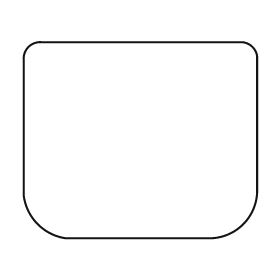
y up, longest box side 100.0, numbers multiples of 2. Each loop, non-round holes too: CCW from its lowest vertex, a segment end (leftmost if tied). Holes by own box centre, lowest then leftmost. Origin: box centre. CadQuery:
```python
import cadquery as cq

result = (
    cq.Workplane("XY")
    .moveTo(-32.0, -42.0)
    .lineTo(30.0, -42.0)
    .threePointArc((44.0, -36.0), (50.0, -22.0))
    .lineTo(50.0, 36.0)
    .threePointArc((48.0, 40.0), (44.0, 42.0))
    .lineTo(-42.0, 42.0)
    .threePointArc((-48.0, 40.0), (-50.0, 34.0))
    .lineTo(-50.0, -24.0)
    .threePointArc((-44.0, -36.0), (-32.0, -42.0))
    .close()
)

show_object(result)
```